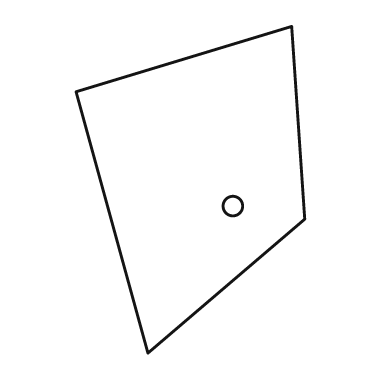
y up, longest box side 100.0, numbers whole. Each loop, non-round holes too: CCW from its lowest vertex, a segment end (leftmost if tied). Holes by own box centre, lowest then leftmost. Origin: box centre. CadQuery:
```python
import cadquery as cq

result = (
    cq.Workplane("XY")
    .moveTo(-13.0, -50.0)
    .lineTo(35.0, -9.0)
    .lineTo(31.0, 50.0)
    .lineTo(-35.0, 30.0)
    .close()
    .moveTo(13.0, -5.0)
    .circle(3.0)
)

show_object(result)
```